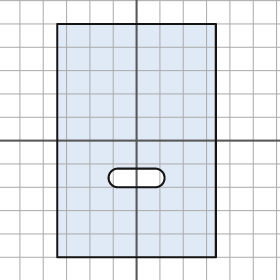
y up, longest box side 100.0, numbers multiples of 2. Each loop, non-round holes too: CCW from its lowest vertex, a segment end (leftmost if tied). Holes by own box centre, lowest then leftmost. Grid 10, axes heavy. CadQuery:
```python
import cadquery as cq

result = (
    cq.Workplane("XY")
    .moveTo(-34.0, -50.0)
    .lineTo(34.0, -50.0)
    .lineTo(34.0, 50.0)
    .lineTo(-34.0, 50.0)
    .close()
    .moveTo(-8.0, -20.0)
    .lineTo(8.0, -20.0)
    .threePointArc((12.0, -16.0), (8.0, -12.0))
    .lineTo(-8.0, -12.0)
    .threePointArc((-12.0, -16.0), (-8.0, -20.0))
    .close()
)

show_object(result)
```